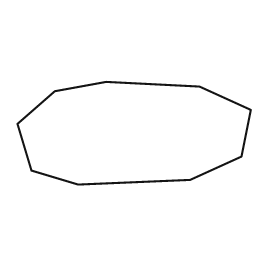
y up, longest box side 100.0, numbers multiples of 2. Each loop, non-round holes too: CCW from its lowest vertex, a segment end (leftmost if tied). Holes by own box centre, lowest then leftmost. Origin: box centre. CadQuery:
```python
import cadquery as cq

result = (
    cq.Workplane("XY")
    .moveTo(-24.0, -22.0)
    .lineTo(24.0, -20.0)
    .lineTo(46.0, -10.0)
    .lineTo(50.0, 10.0)
    .lineTo(28.0, 20.0)
    .lineTo(-12.0, 22.0)
    .lineTo(-34.0, 18.0)
    .lineTo(-50.0, 4.0)
    .lineTo(-44.0, -16.0)
    .close()
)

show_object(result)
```